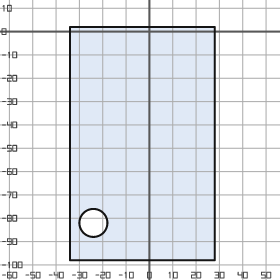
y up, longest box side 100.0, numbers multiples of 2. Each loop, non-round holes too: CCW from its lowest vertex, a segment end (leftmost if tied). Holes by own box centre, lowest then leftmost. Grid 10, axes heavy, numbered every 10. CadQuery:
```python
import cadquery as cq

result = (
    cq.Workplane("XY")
    .moveTo(-34.0, -98.0)
    .lineTo(28.0, -98.0)
    .lineTo(28.0, 2.0)
    .lineTo(-34.0, 2.0)
    .close()
    .moveTo(-24.0, -82.0)
    .circle(6.0)
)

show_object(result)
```